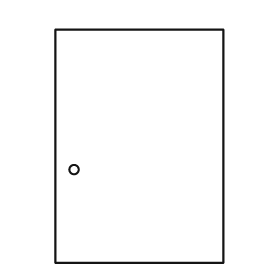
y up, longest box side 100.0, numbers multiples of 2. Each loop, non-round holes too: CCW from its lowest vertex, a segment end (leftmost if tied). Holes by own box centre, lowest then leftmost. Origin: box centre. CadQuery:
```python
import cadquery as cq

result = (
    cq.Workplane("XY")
    .moveTo(-36.0, -50.0)
    .lineTo(36.0, -50.0)
    .lineTo(36.0, 50.0)
    .lineTo(-36.0, 50.0)
    .close()
    .moveTo(-28.0, -10.0)
    .circle(2.0)
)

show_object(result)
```